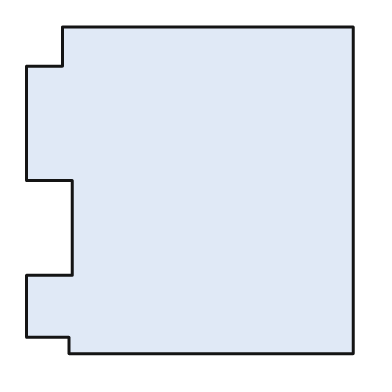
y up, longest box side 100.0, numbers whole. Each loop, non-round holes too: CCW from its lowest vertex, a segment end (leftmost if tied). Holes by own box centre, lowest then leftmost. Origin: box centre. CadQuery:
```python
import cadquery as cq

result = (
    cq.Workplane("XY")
    .moveTo(-37.0, -50.0)
    .lineTo(50.0, -50.0)
    .lineTo(50.0, 50.0)
    .lineTo(-39.0, 50.0)
    .lineTo(-39.0, 38.0)
    .lineTo(-50.0, 38.0)
    .lineTo(-50.0, 3.0)
    .lineTo(-36.0, 3.0)
    .lineTo(-36.0, -26.0)
    .lineTo(-50.0, -26.0)
    .lineTo(-50.0, -45.0)
    .lineTo(-37.0, -45.0)
    .close()
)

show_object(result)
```